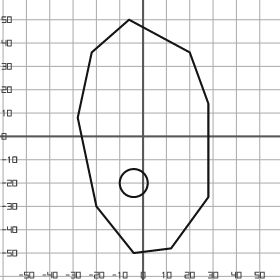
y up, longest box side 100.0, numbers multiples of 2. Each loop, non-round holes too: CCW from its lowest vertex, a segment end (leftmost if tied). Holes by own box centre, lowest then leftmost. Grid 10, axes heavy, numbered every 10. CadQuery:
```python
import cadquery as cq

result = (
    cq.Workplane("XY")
    .moveTo(-4.0, -50.0)
    .lineTo(12.0, -48.0)
    .lineTo(28.0, -26.0)
    .lineTo(28.0, 14.0)
    .lineTo(20.0, 36.0)
    .lineTo(-6.0, 50.0)
    .lineTo(-22.0, 36.0)
    .lineTo(-28.0, 8.0)
    .lineTo(-20.0, -30.0)
    .close()
    .moveTo(-4.0, -20.0)
    .circle(6.0)
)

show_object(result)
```